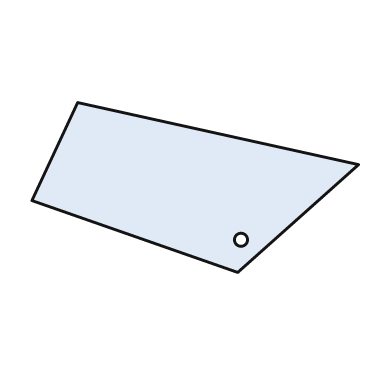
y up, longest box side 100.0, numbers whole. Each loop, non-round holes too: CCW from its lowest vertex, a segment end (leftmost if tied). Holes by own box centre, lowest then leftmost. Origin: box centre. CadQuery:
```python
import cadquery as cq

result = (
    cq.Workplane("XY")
    .moveTo(13.0, -26.0)
    .lineTo(50.0, 7.0)
    .lineTo(-36.0, 26.0)
    .lineTo(-50.0, -4.0)
    .close()
    .moveTo(14.0, -16.0)
    .circle(2.0)
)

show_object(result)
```